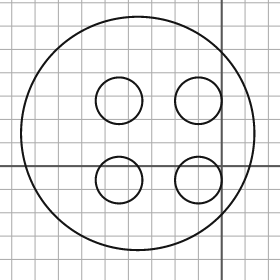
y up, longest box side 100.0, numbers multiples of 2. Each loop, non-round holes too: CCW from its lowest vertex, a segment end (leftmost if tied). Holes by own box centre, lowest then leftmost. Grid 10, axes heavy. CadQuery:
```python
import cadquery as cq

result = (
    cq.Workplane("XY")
    .moveTo(-36.0, 14.0)
    .circle(50.0)
    .moveTo(-44.0, -6.0)
    .circle(10.0)
    .moveTo(-10.0, -6.0)
    .circle(10.0)
    .moveTo(-44.0, 28.0)
    .circle(10.0)
    .moveTo(-10.0, 28.0)
    .circle(10.0)
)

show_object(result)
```